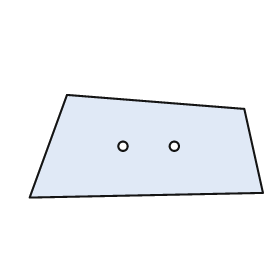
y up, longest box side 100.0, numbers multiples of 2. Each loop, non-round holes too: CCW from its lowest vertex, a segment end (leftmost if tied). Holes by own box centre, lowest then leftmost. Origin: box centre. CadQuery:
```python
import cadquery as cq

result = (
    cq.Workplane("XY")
    .moveTo(-50.0, -22.0)
    .lineTo(50.0, -20.0)
    .lineTo(42.0, 16.0)
    .lineTo(-34.0, 22.0)
    .close()
    .moveTo(-10.0, 0.0)
    .circle(2.0)
    .moveTo(12.0, 0.0)
    .circle(2.0)
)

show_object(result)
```